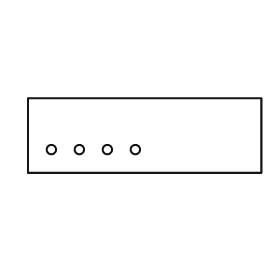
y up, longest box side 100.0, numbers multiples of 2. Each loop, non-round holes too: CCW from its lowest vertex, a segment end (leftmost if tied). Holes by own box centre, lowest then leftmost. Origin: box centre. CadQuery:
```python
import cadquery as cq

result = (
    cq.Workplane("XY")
    .moveTo(-50.0, -16.0)
    .lineTo(50.0, -16.0)
    .lineTo(50.0, 16.0)
    .lineTo(-50.0, 16.0)
    .close()
    .moveTo(-40.0, -6.0)
    .circle(2.0)
    .moveTo(-28.0, -6.0)
    .circle(2.0)
    .moveTo(-16.0, -6.0)
    .circle(2.0)
    .moveTo(-4.0, -6.0)
    .circle(2.0)
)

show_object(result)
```